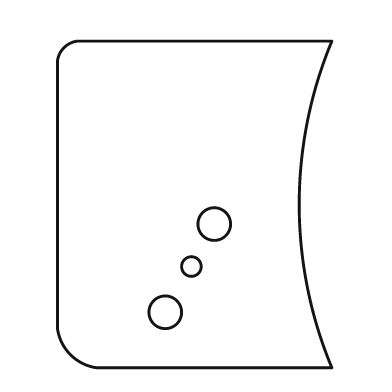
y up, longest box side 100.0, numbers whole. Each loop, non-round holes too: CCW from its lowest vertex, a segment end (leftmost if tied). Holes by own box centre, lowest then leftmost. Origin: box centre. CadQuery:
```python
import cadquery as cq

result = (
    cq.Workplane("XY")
    .moveTo(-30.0, -50.0)
    .lineTo(42.0, -50.0)
    .threePointArc((32.0, 0.0), (42.0, 50.0))
    .lineTo(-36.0, 50.0)
    .threePointArc((-40.0, 48.0), (-42.0, 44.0))
    .lineTo(-42.0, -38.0)
    .threePointArc((-38.0, -46.0), (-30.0, -50.0))
    .close()
    .moveTo(-9.0, -33.0)
    .circle(5.0)
    .moveTo(-1.0, -19.0)
    .circle(3.0)
    .moveTo(6.0, -6.0)
    .circle(5.0)
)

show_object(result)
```